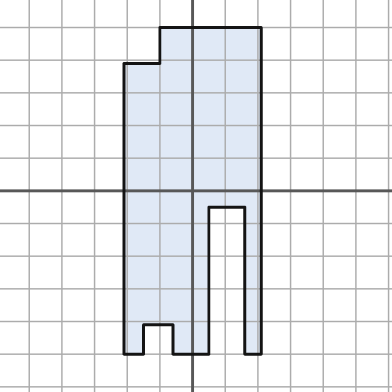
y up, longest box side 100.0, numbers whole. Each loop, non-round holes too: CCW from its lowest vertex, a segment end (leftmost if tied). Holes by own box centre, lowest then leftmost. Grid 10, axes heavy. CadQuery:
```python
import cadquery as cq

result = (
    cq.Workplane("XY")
    .moveTo(-21.0, -50.0)
    .lineTo(-15.0, -50.0)
    .lineTo(-15.0, -41.0)
    .lineTo(-6.0, -41.0)
    .lineTo(-6.0, -50.0)
    .lineTo(5.0, -50.0)
    .lineTo(5.0, -5.0)
    .lineTo(16.0, -5.0)
    .lineTo(16.0, -50.0)
    .lineTo(21.0, -50.0)
    .lineTo(21.0, 50.0)
    .lineTo(-10.0, 50.0)
    .lineTo(-10.0, 39.0)
    .lineTo(-21.0, 39.0)
    .close()
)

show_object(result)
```